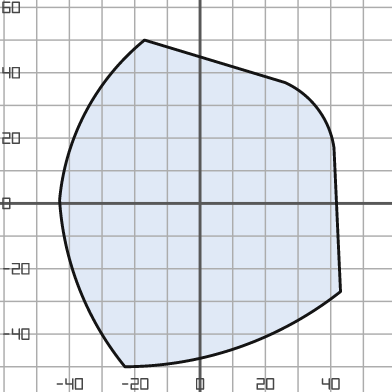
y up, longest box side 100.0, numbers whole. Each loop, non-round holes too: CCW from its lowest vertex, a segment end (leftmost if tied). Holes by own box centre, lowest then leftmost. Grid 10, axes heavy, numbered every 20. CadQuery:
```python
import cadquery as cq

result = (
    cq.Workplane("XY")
    .moveTo(-23.0, -50.0)
    .threePointArc((12.0, -44.0), (43.0, -27.0))
    .lineTo(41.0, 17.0)
    .threePointArc((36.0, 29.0), (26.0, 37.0))
    .lineTo(-17.0, 50.0)
    .threePointArc((-35.0, 28.0), (-43.0, 1.0))
    .threePointArc((-37.0, -26.0), (-23.0, -50.0))
    .close()
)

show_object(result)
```